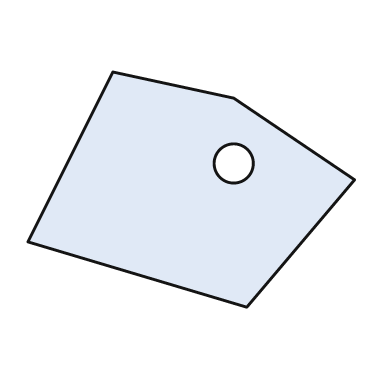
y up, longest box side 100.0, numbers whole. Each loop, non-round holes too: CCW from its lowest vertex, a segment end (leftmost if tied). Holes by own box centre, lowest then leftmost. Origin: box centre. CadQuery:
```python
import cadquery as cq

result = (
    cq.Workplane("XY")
    .moveTo(17.0, -36.0)
    .lineTo(50.0, 3.0)
    .lineTo(13.0, 28.0)
    .lineTo(-24.0, 36.0)
    .lineTo(-50.0, -16.0)
    .close()
    .moveTo(13.0, 8.0)
    .circle(6.0)
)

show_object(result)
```